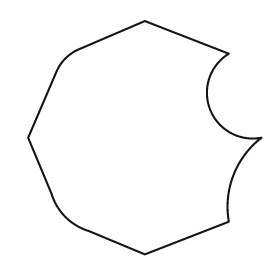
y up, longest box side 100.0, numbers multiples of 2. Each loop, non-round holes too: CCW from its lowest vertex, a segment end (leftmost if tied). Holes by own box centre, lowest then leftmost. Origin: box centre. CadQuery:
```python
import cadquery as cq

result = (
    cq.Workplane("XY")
    .moveTo(0.0, -50.0)
    .lineTo(36.0, -36.0)
    .threePointArc((38.0, -16.0), (50.0, 0.0))
    .threePointArc((28.0, 12.0), (36.0, 36.0))
    .lineTo(0.0, 50.0)
    .lineTo(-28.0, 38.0)
    .threePointArc((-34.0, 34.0), (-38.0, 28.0))
    .lineTo(-50.0, 0.0)
    .lineTo(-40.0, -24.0)
    .threePointArc((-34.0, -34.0), (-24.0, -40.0))
    .close()
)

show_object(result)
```